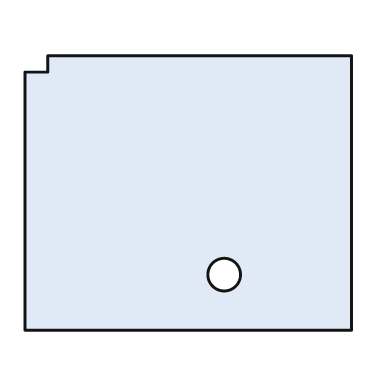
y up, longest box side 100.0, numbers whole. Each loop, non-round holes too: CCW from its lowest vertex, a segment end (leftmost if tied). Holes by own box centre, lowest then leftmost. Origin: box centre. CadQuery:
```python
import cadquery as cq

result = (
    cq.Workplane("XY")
    .moveTo(-50.0, -42.0)
    .lineTo(50.0, -42.0)
    .lineTo(50.0, 42.0)
    .lineTo(-43.0, 42.0)
    .lineTo(-43.0, 37.0)
    .lineTo(-50.0, 37.0)
    .close()
    .moveTo(11.0, -25.0)
    .circle(5.0)
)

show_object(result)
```